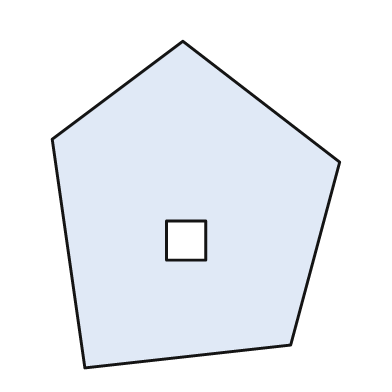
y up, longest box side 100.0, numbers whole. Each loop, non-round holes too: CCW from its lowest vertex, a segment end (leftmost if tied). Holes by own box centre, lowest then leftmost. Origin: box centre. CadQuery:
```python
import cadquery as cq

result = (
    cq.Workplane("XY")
    .moveTo(-34.0, -50.0)
    .lineTo(29.0, -43.0)
    .lineTo(44.0, 13.0)
    .lineTo(-4.0, 50.0)
    .lineTo(-44.0, 20.0)
    .close()
    .moveTo(-9.0, -17.0)
    .lineTo(3.0, -17.0)
    .lineTo(3.0, -5.0)
    .lineTo(-9.0, -5.0)
    .close()
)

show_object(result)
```